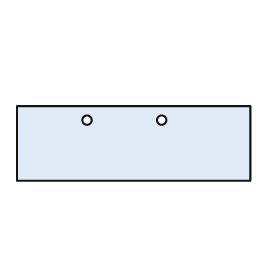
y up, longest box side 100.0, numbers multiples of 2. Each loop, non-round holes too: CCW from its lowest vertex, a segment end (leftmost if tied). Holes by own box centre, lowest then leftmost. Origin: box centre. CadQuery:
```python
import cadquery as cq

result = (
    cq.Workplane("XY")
    .moveTo(-50.0, -16.0)
    .lineTo(50.0, -16.0)
    .lineTo(50.0, 16.0)
    .lineTo(-50.0, 16.0)
    .close()
    .moveTo(-20.0, 10.0)
    .circle(2.0)
    .moveTo(12.0, 10.0)
    .circle(2.0)
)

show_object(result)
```